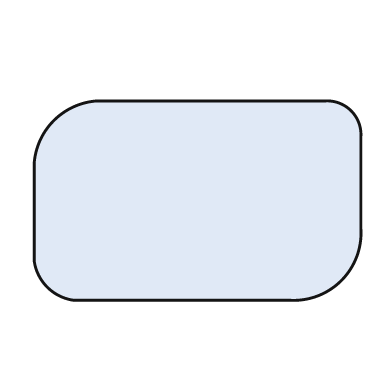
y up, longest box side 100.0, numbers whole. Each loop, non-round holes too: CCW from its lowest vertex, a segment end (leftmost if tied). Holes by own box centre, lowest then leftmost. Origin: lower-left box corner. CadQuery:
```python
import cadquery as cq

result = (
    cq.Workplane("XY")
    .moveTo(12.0, 0.0)
    .lineTo(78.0, 0.0)
    .threePointArc((94.0, 6.0), (100.0, 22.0))
    .lineTo(100.0, 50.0)
    .threePointArc((97.0, 58.0), (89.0, 61.0))
    .lineTo(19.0, 61.0)
    .threePointArc((6.0, 55.0), (0.0, 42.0))
    .lineTo(0.0, 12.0)
    .threePointArc((4.0, 4.0), (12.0, 0.0))
    .close()
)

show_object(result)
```